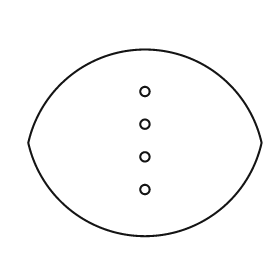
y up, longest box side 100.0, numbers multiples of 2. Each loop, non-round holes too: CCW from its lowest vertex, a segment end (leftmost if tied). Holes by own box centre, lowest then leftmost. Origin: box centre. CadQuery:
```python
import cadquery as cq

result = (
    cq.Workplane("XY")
    .moveTo(-50.0, 0.0)
    .threePointArc((0.0, -40.0), (50.0, 0.0))
    .threePointArc((0.0, 40.0), (-50.0, 0.0))
    .close()
    .moveTo(0.0, -20.0)
    .circle(2.0)
    .moveTo(0.0, -6.0)
    .circle(2.0)
    .moveTo(0.0, 8.0)
    .circle(2.0)
    .moveTo(0.0, 22.0)
    .circle(2.0)
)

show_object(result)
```